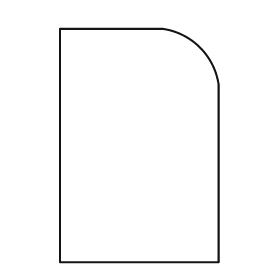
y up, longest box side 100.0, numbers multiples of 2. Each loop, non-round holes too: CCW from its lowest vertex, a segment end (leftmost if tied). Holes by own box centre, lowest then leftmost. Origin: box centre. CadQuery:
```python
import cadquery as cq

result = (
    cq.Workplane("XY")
    .moveTo(-34.0, -50.0)
    .lineTo(34.0, -50.0)
    .lineTo(34.0, 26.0)
    .threePointArc((26.0, 42.0), (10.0, 50.0))
    .lineTo(-34.0, 50.0)
    .close()
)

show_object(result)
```